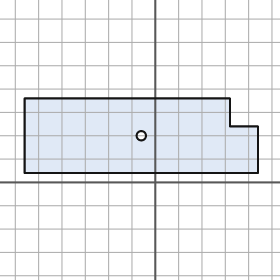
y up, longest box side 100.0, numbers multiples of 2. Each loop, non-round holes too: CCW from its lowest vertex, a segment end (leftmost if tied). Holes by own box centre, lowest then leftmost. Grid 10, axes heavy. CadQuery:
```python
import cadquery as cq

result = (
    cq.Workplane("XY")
    .moveTo(-56.0, 4.0)
    .lineTo(44.0, 4.0)
    .lineTo(44.0, 24.0)
    .lineTo(32.0, 24.0)
    .lineTo(32.0, 36.0)
    .lineTo(-56.0, 36.0)
    .close()
    .moveTo(-6.0, 20.0)
    .circle(2.0)
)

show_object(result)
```